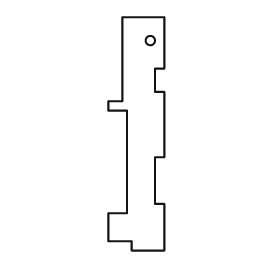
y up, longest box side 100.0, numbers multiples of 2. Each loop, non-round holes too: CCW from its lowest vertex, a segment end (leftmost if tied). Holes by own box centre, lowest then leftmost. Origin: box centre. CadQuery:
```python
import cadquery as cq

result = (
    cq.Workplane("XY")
    .moveTo(-2.0, -50.0)
    .lineTo(12.0, -50.0)
    .lineTo(12.0, -30.0)
    .lineTo(8.0, -30.0)
    .lineTo(8.0, -10.0)
    .lineTo(12.0, -10.0)
    .lineTo(12.0, 18.0)
    .lineTo(8.0, 18.0)
    .lineTo(8.0, 28.0)
    .lineTo(12.0, 28.0)
    .lineTo(12.0, 50.0)
    .lineTo(-6.0, 50.0)
    .lineTo(-6.0, 14.0)
    .lineTo(-12.0, 14.0)
    .lineTo(-12.0, 10.0)
    .lineTo(-4.0, 10.0)
    .lineTo(-4.0, -34.0)
    .lineTo(-12.0, -34.0)
    .lineTo(-12.0, -46.0)
    .lineTo(-2.0, -46.0)
    .close()
    .moveTo(6.0, 40.0)
    .circle(2.0)
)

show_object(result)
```